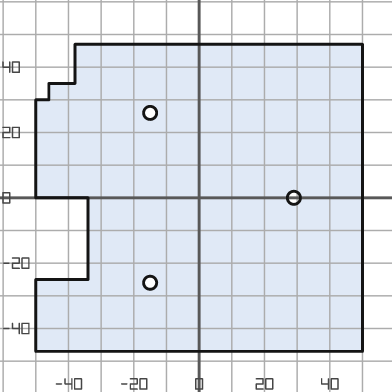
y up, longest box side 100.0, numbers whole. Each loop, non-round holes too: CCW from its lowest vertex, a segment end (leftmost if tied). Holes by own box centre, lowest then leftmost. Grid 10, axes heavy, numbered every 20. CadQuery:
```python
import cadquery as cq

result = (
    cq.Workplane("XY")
    .moveTo(-50.0, -47.0)
    .lineTo(50.0, -47.0)
    .lineTo(50.0, 47.0)
    .lineTo(-38.0, 47.0)
    .lineTo(-38.0, 35.0)
    .lineTo(-46.0, 35.0)
    .lineTo(-46.0, 30.0)
    .lineTo(-50.0, 30.0)
    .lineTo(-50.0, 0.0)
    .lineTo(-34.0, 0.0)
    .lineTo(-34.0, -25.0)
    .lineTo(-50.0, -25.0)
    .close()
    .moveTo(-15.0, -26.0)
    .circle(2.0)
    .moveTo(29.0, 0.0)
    .circle(2.0)
    .moveTo(-15.0, 26.0)
    .circle(2.0)
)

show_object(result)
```